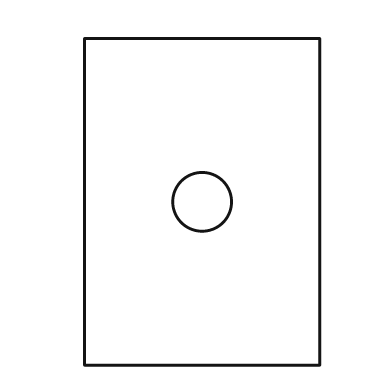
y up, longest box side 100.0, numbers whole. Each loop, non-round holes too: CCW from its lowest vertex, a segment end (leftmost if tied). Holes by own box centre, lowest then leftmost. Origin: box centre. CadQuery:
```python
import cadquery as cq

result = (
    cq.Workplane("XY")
    .moveTo(-36.0, -50.0)
    .lineTo(36.0, -50.0)
    .lineTo(36.0, 50.0)
    .lineTo(-36.0, 50.0)
    .close()
    .moveTo(0.0, 0.0)
    .circle(9.0)
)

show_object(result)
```